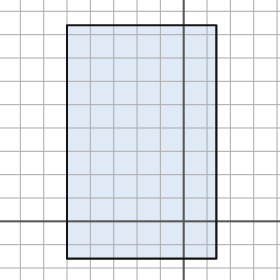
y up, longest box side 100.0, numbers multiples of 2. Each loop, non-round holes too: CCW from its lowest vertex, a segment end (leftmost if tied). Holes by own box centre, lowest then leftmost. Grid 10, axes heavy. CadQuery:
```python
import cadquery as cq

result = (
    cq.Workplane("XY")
    .moveTo(-50.0, -16.0)
    .lineTo(14.0, -16.0)
    .lineTo(14.0, 84.0)
    .lineTo(-50.0, 84.0)
    .close()
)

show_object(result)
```